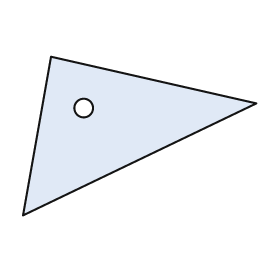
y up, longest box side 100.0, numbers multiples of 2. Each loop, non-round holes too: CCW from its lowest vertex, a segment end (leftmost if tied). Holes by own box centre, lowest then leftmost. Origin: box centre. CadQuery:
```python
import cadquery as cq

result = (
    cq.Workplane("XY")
    .moveTo(-50.0, -34.0)
    .lineTo(50.0, 14.0)
    .lineTo(-38.0, 34.0)
    .close()
    .moveTo(-24.0, 12.0)
    .circle(4.0)
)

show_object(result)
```